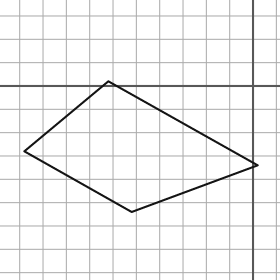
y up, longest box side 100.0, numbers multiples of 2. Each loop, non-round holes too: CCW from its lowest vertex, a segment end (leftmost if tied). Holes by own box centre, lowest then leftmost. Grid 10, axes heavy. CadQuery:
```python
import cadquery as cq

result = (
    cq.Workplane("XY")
    .moveTo(-52.0, -54.0)
    .lineTo(2.0, -34.0)
    .lineTo(-62.0, 2.0)
    .lineTo(-98.0, -28.0)
    .close()
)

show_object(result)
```